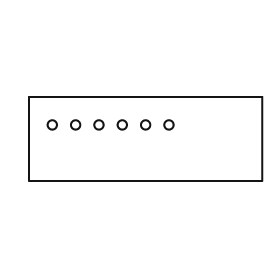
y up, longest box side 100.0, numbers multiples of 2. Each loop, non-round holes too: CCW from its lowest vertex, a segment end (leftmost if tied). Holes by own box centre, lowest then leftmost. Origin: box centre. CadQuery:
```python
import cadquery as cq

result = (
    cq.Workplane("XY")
    .moveTo(-50.0, -18.0)
    .lineTo(50.0, -18.0)
    .lineTo(50.0, 18.0)
    .lineTo(-50.0, 18.0)
    .close()
    .moveTo(-40.0, 6.0)
    .circle(2.0)
    .moveTo(-30.0, 6.0)
    .circle(2.0)
    .moveTo(-20.0, 6.0)
    .circle(2.0)
    .moveTo(-10.0, 6.0)
    .circle(2.0)
    .moveTo(0.0, 6.0)
    .circle(2.0)
    .moveTo(10.0, 6.0)
    .circle(2.0)
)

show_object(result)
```